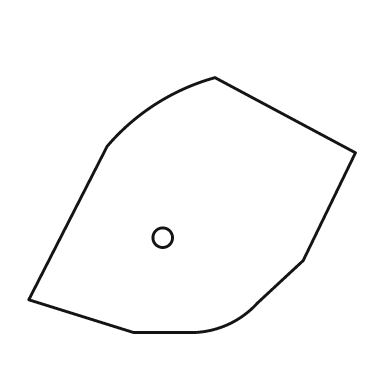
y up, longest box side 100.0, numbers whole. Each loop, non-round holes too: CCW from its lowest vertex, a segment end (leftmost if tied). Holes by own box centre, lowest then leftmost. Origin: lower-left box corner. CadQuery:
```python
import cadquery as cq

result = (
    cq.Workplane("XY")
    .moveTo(32.0, 0.0)
    .lineTo(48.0, 0.0)
    .threePointArc((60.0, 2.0), (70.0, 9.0))
    .lineTo(84.0, 22.0)
    .lineTo(100.0, 55.0)
    .lineTo(57.0, 78.0)
    .threePointArc((39.0, 70.0), (24.0, 57.0))
    .lineTo(0.0, 10.0)
    .close()
    .moveTo(41.0, 29.0)
    .circle(3.0)
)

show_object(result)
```